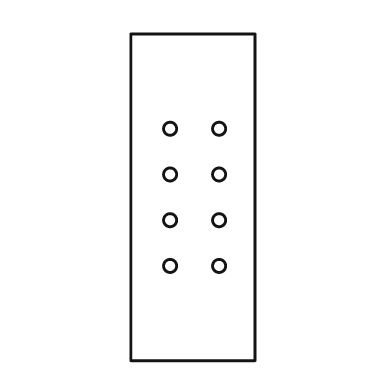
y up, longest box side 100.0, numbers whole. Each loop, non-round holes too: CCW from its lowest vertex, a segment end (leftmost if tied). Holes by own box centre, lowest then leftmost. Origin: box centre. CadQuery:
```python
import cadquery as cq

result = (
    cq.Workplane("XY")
    .moveTo(-19.0, -50.0)
    .lineTo(19.0, -50.0)
    .lineTo(19.0, 50.0)
    .lineTo(-19.0, 50.0)
    .close()
    .moveTo(-7.0, -21.0)
    .circle(2.0)
    .moveTo(8.0, -21.0)
    .circle(2.0)
    .moveTo(-7.0, -7.0)
    .circle(2.0)
    .moveTo(8.0, -7.0)
    .circle(2.0)
    .moveTo(-7.0, 7.0)
    .circle(2.0)
    .moveTo(8.0, 7.0)
    .circle(2.0)
    .moveTo(-7.0, 21.0)
    .circle(2.0)
    .moveTo(8.0, 21.0)
    .circle(2.0)
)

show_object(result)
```